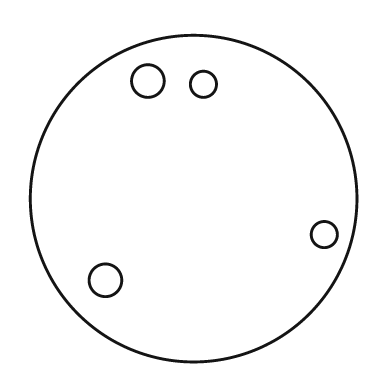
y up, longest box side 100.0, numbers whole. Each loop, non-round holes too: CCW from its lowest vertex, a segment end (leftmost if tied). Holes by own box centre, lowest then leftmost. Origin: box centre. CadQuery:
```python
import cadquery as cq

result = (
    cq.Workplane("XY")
    .moveTo(0.0, 0.0)
    .circle(50.0)
    .moveTo(-27.0, -25.0)
    .circle(5.0)
    .moveTo(40.0, -11.0)
    .circle(4.0)
    .moveTo(3.0, 35.0)
    .circle(4.0)
    .moveTo(-14.0, 36.0)
    .circle(5.0)
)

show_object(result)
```